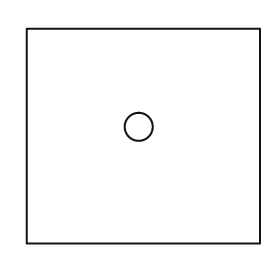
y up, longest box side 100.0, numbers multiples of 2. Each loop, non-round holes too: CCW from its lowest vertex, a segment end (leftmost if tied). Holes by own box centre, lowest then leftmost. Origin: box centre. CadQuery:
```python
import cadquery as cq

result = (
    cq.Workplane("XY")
    .moveTo(-50.0, -46.0)
    .lineTo(50.0, -46.0)
    .lineTo(50.0, 46.0)
    .lineTo(-50.0, 46.0)
    .close()
    .moveTo(-2.0, 4.0)
    .circle(6.0)
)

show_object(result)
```